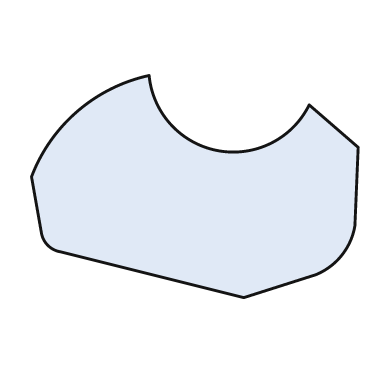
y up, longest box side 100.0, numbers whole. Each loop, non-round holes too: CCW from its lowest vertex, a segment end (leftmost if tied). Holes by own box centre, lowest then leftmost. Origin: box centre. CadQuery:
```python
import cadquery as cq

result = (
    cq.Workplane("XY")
    .moveTo(15.0, -34.0)
    .lineTo(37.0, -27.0)
    .threePointArc((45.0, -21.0), (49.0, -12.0))
    .lineTo(50.0, 12.0)
    .lineTo(35.0, 25.0)
    .threePointArc((7.0, 11.0), (-14.0, 34.0))
    .threePointArc((-36.0, 23.0), (-50.0, 3.0))
    .lineTo(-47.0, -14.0)
    .threePointArc((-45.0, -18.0), (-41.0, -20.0))
    .close()
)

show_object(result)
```